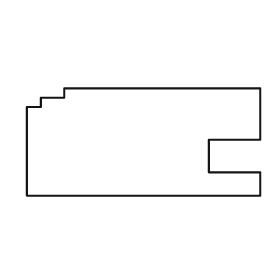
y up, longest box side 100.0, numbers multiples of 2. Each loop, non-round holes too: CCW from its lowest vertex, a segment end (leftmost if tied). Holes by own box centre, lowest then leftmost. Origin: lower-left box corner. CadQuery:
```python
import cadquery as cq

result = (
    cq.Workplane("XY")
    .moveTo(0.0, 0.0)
    .lineTo(100.0, 0.0)
    .lineTo(100.0, 10.0)
    .lineTo(78.0, 10.0)
    .lineTo(78.0, 24.0)
    .lineTo(100.0, 24.0)
    .lineTo(100.0, 46.0)
    .lineTo(16.0, 46.0)
    .lineTo(16.0, 42.0)
    .lineTo(6.0, 42.0)
    .lineTo(6.0, 38.0)
    .lineTo(0.0, 38.0)
    .close()
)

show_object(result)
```